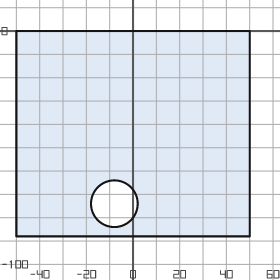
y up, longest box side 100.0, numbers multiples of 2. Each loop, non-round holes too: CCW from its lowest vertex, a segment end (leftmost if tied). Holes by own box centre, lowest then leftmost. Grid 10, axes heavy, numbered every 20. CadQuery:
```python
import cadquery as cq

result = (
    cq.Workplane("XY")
    .moveTo(-50.0, -88.0)
    .lineTo(50.0, -88.0)
    .lineTo(50.0, 0.0)
    .lineTo(-50.0, 0.0)
    .close()
    .moveTo(-8.0, -74.0)
    .circle(10.0)
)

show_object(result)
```